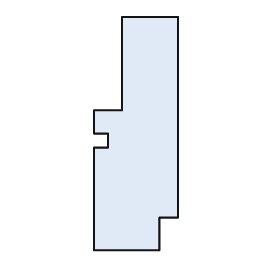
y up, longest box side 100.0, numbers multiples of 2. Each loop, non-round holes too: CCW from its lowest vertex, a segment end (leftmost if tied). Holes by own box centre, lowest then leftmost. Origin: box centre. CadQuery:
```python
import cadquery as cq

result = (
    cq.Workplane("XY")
    .moveTo(-18.0, -50.0)
    .lineTo(10.0, -50.0)
    .lineTo(10.0, -36.0)
    .lineTo(18.0, -36.0)
    .lineTo(18.0, 50.0)
    .lineTo(-6.0, 50.0)
    .lineTo(-6.0, 10.0)
    .lineTo(-18.0, 10.0)
    .lineTo(-18.0, 0.0)
    .lineTo(-12.0, 0.0)
    .lineTo(-12.0, -6.0)
    .lineTo(-18.0, -6.0)
    .close()
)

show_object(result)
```